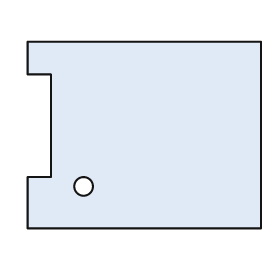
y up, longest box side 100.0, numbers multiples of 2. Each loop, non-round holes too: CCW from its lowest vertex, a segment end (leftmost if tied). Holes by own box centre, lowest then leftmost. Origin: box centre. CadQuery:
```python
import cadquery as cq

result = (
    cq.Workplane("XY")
    .moveTo(-50.0, -40.0)
    .lineTo(50.0, -40.0)
    .lineTo(50.0, 40.0)
    .lineTo(-50.0, 40.0)
    .lineTo(-50.0, 26.0)
    .lineTo(-40.0, 26.0)
    .lineTo(-40.0, -18.0)
    .lineTo(-50.0, -18.0)
    .close()
    .moveTo(-26.0, -22.0)
    .circle(4.0)
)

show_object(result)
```